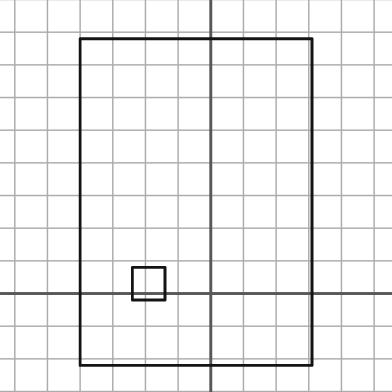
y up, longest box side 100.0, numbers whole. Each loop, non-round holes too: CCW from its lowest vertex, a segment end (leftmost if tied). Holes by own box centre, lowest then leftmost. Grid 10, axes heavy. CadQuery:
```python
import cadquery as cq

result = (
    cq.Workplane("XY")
    .moveTo(-40.0, -22.0)
    .lineTo(31.0, -22.0)
    .lineTo(31.0, 78.0)
    .lineTo(-40.0, 78.0)
    .close()
    .moveTo(-24.0, -2.0)
    .lineTo(-14.0, -2.0)
    .lineTo(-14.0, 8.0)
    .lineTo(-24.0, 8.0)
    .close()
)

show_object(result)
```